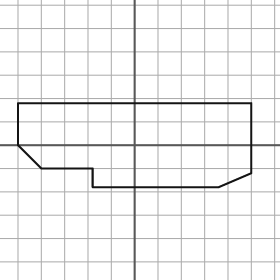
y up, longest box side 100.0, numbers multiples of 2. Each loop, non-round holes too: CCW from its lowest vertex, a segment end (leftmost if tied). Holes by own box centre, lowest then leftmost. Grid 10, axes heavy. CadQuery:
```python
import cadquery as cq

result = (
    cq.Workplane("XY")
    .moveTo(-18.0, -18.0)
    .lineTo(36.0, -18.0)
    .lineTo(50.0, -12.0)
    .lineTo(50.0, 18.0)
    .lineTo(-50.0, 18.0)
    .lineTo(-50.0, 0.0)
    .lineTo(-40.0, -10.0)
    .lineTo(-18.0, -10.0)
    .close()
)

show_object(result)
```